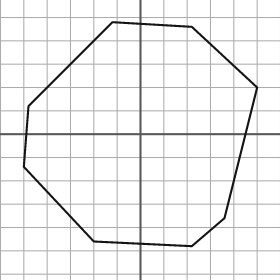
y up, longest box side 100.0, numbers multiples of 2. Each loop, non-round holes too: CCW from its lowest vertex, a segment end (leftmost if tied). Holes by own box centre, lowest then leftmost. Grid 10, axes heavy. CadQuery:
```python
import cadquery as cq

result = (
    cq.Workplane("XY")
    .moveTo(22.0, -48.0)
    .lineTo(36.0, -36.0)
    .lineTo(50.0, 20.0)
    .lineTo(22.0, 46.0)
    .lineTo(-12.0, 48.0)
    .lineTo(-48.0, 12.0)
    .lineTo(-50.0, -14.0)
    .lineTo(-20.0, -46.0)
    .close()
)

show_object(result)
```